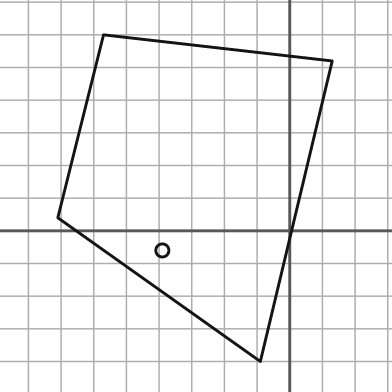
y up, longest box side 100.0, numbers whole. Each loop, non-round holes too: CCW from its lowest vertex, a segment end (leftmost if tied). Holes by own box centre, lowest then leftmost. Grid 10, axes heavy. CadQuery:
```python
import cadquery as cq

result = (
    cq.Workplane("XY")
    .moveTo(-9.0, -40.0)
    .lineTo(13.0, 52.0)
    .lineTo(-57.0, 60.0)
    .lineTo(-71.0, 4.0)
    .close()
    .moveTo(-39.0, -6.0)
    .circle(2.0)
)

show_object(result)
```